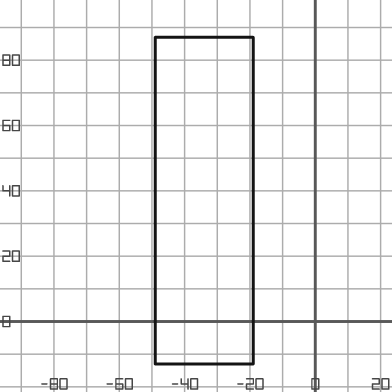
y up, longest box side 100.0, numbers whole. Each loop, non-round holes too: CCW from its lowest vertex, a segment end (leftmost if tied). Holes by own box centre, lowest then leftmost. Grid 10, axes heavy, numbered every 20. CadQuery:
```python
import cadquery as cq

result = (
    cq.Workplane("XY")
    .moveTo(-49.0, -13.0)
    .lineTo(-19.0, -13.0)
    .lineTo(-19.0, 87.0)
    .lineTo(-49.0, 87.0)
    .close()
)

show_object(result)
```